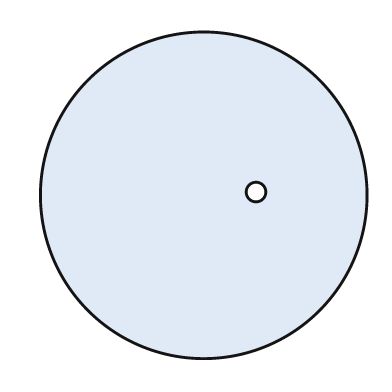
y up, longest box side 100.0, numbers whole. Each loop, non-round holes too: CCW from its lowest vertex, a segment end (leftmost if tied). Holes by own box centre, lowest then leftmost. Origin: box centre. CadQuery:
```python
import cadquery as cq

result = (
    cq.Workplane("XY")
    .moveTo(0.0, 0.0)
    .circle(50.0)
    .moveTo(16.0, 1.0)
    .circle(3.0)
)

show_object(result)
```